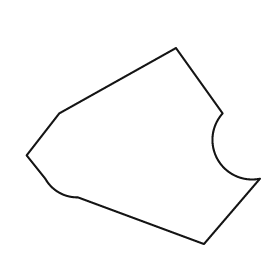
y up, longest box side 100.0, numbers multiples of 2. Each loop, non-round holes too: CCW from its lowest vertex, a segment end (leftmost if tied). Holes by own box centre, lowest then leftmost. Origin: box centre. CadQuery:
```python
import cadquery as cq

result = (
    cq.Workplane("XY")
    .moveTo(26.0, -42.0)
    .lineTo(50.0, -14.0)
    .threePointArc((32.0, -6.0), (34.0, 14.0))
    .lineTo(14.0, 42.0)
    .lineTo(-36.0, 14.0)
    .lineTo(-50.0, -4.0)
    .lineTo(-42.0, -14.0)
    .threePointArc((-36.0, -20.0), (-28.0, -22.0))
    .close()
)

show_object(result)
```